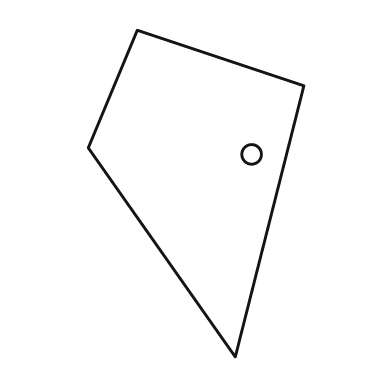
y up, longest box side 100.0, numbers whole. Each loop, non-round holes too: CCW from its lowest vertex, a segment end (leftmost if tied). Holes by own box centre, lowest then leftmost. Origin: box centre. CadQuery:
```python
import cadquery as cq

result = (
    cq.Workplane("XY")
    .moveTo(12.0, -50.0)
    .lineTo(33.0, 33.0)
    .lineTo(-18.0, 50.0)
    .lineTo(-33.0, 14.0)
    .close()
    .moveTo(17.0, 12.0)
    .circle(3.0)
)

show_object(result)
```